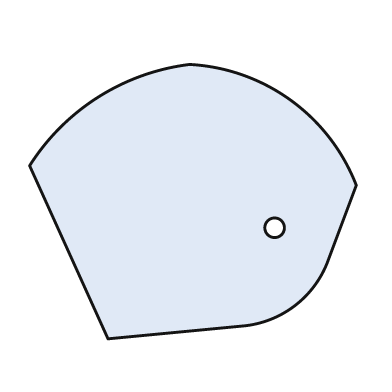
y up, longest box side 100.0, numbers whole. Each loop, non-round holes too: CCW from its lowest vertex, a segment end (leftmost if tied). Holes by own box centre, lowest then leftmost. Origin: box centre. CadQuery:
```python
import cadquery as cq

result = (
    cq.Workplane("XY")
    .moveTo(-26.0, -42.0)
    .lineTo(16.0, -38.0)
    .threePointArc((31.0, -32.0), (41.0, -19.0))
    .lineTo(50.0, 5.0)
    .threePointArc((30.0, 31.0), (-1.0, 42.0))
    .threePointArc((-29.0, 32.0), (-50.0, 11.0))
    .close()
    .moveTo(25.0, -8.0)
    .circle(3.0)
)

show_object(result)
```